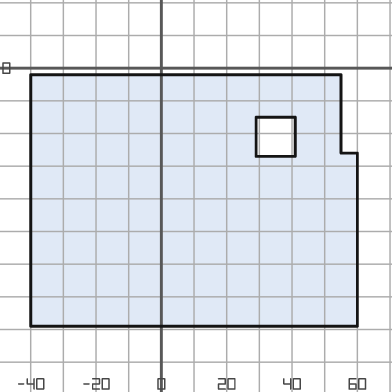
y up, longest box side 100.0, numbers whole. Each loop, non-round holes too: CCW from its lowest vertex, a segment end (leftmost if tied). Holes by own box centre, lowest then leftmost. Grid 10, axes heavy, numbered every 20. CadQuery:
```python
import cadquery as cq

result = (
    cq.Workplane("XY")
    .moveTo(-40.0, -79.0)
    .lineTo(60.0, -79.0)
    .lineTo(60.0, -26.0)
    .lineTo(55.0, -26.0)
    .lineTo(55.0, -2.0)
    .lineTo(-40.0, -2.0)
    .close()
    .moveTo(29.0, -27.0)
    .lineTo(41.0, -27.0)
    .lineTo(41.0, -15.0)
    .lineTo(29.0, -15.0)
    .close()
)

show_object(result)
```